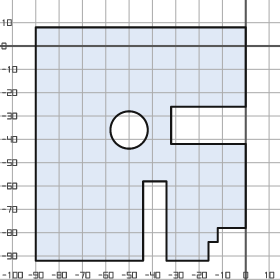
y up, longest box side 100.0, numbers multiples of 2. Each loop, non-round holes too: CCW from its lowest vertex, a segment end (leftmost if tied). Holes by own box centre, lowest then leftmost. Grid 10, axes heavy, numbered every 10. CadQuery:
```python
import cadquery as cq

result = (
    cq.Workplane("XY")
    .moveTo(-90.0, -92.0)
    .lineTo(-44.0, -92.0)
    .lineTo(-44.0, -58.0)
    .lineTo(-34.0, -58.0)
    .lineTo(-34.0, -92.0)
    .lineTo(-16.0, -92.0)
    .lineTo(-16.0, -84.0)
    .lineTo(-12.0, -84.0)
    .lineTo(-12.0, -78.0)
    .lineTo(0.0, -78.0)
    .lineTo(0.0, -42.0)
    .lineTo(-32.0, -42.0)
    .lineTo(-32.0, -26.0)
    .lineTo(0.0, -26.0)
    .lineTo(0.0, 8.0)
    .lineTo(-90.0, 8.0)
    .close()
    .moveTo(-50.0, -36.0)
    .circle(8.0)
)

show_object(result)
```